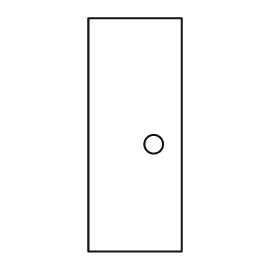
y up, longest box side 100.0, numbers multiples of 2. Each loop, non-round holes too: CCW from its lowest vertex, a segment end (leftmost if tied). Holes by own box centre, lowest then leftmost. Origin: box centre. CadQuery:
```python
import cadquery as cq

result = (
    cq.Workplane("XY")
    .moveTo(-20.0, -50.0)
    .lineTo(20.0, -50.0)
    .lineTo(20.0, 50.0)
    .lineTo(-20.0, 50.0)
    .close()
    .moveTo(8.0, -4.0)
    .circle(4.0)
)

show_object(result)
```